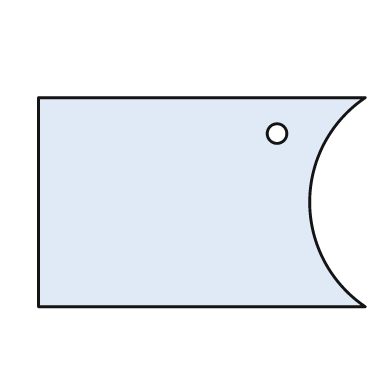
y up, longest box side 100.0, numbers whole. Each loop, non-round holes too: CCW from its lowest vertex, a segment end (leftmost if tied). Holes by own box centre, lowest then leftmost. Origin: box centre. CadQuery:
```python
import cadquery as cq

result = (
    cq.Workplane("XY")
    .moveTo(-50.0, -32.0)
    .lineTo(50.0, -32.0)
    .threePointArc((33.0, 0.0), (50.0, 32.0))
    .lineTo(-50.0, 32.0)
    .close()
    .moveTo(23.0, 21.0)
    .circle(3.0)
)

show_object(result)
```